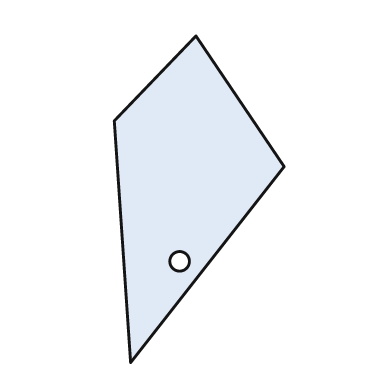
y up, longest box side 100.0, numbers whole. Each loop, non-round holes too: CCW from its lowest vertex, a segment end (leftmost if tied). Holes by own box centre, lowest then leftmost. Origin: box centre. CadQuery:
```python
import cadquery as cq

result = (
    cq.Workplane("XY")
    .moveTo(-21.0, -50.0)
    .lineTo(26.0, 10.0)
    .lineTo(-1.0, 50.0)
    .lineTo(-26.0, 24.0)
    .close()
    .moveTo(-6.0, -19.0)
    .circle(3.0)
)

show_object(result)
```